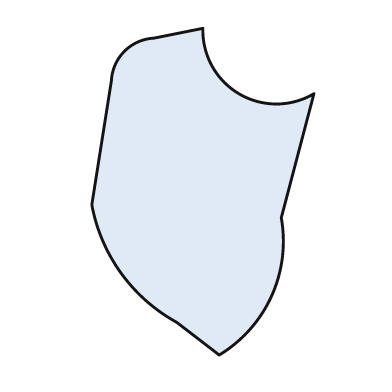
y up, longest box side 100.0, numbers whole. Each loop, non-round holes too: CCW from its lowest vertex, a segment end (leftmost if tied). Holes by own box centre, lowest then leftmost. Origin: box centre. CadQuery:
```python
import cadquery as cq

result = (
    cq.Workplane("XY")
    .moveTo(5.0, -50.0)
    .threePointArc((21.0, -32.0), (24.0, -8.0))
    .lineTo(34.0, 30.0)
    .threePointArc((11.0, 30.0), (0.0, 50.0))
    .lineTo(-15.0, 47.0)
    .threePointArc((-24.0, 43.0), (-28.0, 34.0))
    .lineTo(-34.0, -4.0)
    .threePointArc((-25.0, -25.0), (-8.0, -40.0))
    .close()
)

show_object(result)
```